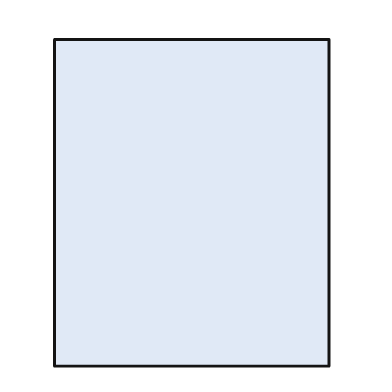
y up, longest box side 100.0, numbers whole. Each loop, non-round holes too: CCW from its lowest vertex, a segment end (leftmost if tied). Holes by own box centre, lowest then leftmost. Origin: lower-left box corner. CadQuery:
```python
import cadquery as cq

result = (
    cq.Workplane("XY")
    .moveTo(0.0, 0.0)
    .lineTo(84.0, 0.0)
    .lineTo(84.0, 100.0)
    .lineTo(0.0, 100.0)
    .close()
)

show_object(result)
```